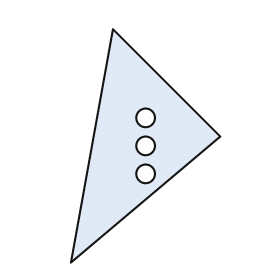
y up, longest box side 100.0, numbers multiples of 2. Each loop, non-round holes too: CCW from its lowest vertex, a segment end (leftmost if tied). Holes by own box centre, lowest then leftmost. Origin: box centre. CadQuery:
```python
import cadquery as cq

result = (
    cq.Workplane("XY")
    .moveTo(-32.0, -50.0)
    .lineTo(32.0, 4.0)
    .lineTo(-14.0, 50.0)
    .close()
    .moveTo(0.0, -12.0)
    .circle(4.0)
    .moveTo(0.0, 0.0)
    .circle(4.0)
    .moveTo(0.0, 12.0)
    .circle(4.0)
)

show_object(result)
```